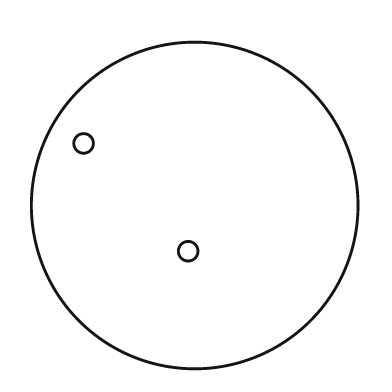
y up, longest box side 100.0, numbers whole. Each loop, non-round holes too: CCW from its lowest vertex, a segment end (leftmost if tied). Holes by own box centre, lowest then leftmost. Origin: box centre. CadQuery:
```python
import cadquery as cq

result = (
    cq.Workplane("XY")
    .moveTo(0.0, 0.0)
    .circle(50.0)
    .moveTo(-2.0, -14.0)
    .circle(3.0)
    .moveTo(-34.0, 19.0)
    .circle(3.0)
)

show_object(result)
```